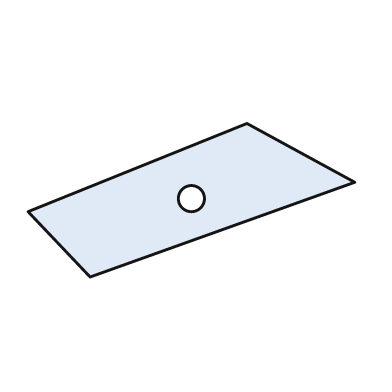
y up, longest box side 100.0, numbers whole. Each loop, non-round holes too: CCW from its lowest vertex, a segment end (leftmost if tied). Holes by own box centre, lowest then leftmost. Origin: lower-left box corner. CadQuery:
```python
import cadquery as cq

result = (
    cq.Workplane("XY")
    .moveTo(19.0, 0.0)
    .lineTo(100.0, 29.0)
    .lineTo(67.0, 47.0)
    .lineTo(0.0, 20.0)
    .close()
    .moveTo(50.0, 24.0)
    .circle(4.0)
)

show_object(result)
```